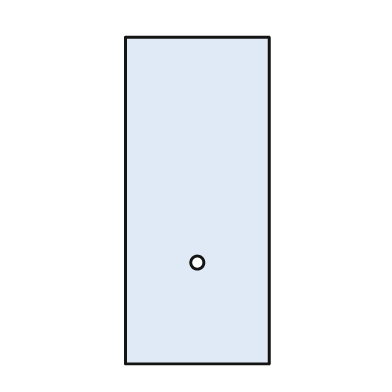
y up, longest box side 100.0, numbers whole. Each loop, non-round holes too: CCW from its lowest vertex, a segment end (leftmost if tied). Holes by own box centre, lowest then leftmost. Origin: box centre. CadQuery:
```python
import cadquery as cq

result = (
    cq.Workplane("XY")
    .moveTo(-22.0, -50.0)
    .lineTo(22.0, -50.0)
    .lineTo(22.0, 50.0)
    .lineTo(-22.0, 50.0)
    .close()
    .moveTo(0.0, -19.0)
    .circle(2.0)
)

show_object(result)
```